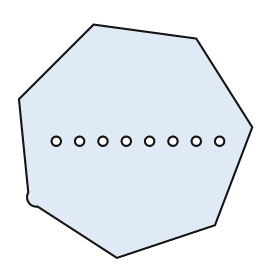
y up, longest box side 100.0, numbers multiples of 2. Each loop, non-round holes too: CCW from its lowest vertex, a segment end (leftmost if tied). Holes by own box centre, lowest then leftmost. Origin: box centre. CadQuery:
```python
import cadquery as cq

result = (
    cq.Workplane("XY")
    .moveTo(-8.0, -50.0)
    .lineTo(34.0, -36.0)
    .lineTo(50.0, 6.0)
    .lineTo(26.0, 44.0)
    .lineTo(-18.0, 50.0)
    .lineTo(-50.0, 18.0)
    .lineTo(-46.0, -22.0)
    .threePointArc((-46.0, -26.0), (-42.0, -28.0))
    .close()
    .moveTo(-34.0, 0.0)
    .circle(2.0)
    .moveTo(-24.0, 0.0)
    .circle(2.0)
    .moveTo(-14.0, 0.0)
    .circle(2.0)
    .moveTo(-4.0, 0.0)
    .circle(2.0)
    .moveTo(6.0, 0.0)
    .circle(2.0)
    .moveTo(16.0, 0.0)
    .circle(2.0)
    .moveTo(26.0, 0.0)
    .circle(2.0)
    .moveTo(36.0, 0.0)
    .circle(2.0)
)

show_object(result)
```